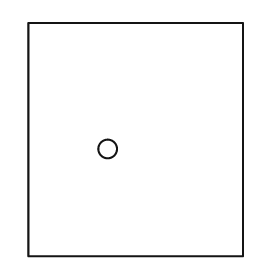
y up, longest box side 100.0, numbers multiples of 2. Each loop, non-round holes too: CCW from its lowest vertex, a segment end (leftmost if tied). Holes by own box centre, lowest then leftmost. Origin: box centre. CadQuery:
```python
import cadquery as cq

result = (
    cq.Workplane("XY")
    .moveTo(-46.0, -50.0)
    .lineTo(46.0, -50.0)
    .lineTo(46.0, 50.0)
    .lineTo(-46.0, 50.0)
    .close()
    .moveTo(-12.0, -4.0)
    .circle(4.0)
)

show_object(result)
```